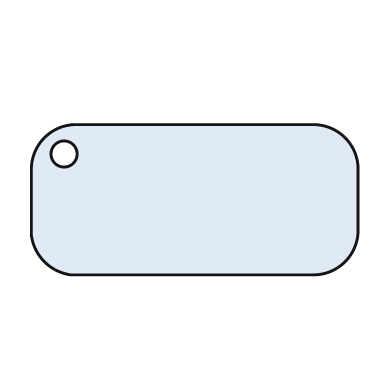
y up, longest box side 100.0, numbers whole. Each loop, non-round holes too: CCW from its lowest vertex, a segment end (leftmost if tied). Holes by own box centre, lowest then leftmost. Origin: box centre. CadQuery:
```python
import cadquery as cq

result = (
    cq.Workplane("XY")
    .moveTo(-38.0, -23.0)
    .lineTo(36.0, -23.0)
    .threePointArc((46.0, -19.0), (50.0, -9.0))
    .lineTo(50.0, 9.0)
    .threePointArc((46.0, 19.0), (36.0, 23.0))
    .lineTo(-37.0, 23.0)
    .threePointArc((-46.0, 19.0), (-50.0, 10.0))
    .lineTo(-50.0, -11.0)
    .threePointArc((-46.0, -19.0), (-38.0, -23.0))
    .close()
    .moveTo(-40.0, 14.0)
    .circle(4.0)
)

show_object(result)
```